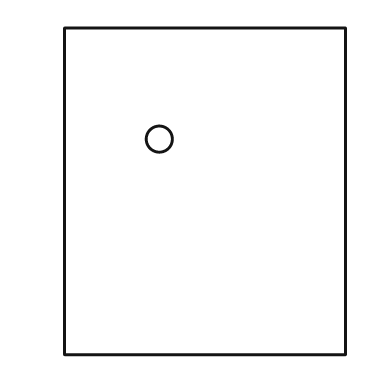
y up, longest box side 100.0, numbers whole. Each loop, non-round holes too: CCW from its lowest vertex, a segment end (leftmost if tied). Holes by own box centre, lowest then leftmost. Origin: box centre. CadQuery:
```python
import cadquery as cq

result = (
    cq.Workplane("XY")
    .moveTo(-43.0, -50.0)
    .lineTo(43.0, -50.0)
    .lineTo(43.0, 50.0)
    .lineTo(-43.0, 50.0)
    .close()
    .moveTo(-14.0, 16.0)
    .circle(4.0)
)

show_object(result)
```